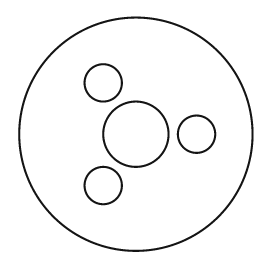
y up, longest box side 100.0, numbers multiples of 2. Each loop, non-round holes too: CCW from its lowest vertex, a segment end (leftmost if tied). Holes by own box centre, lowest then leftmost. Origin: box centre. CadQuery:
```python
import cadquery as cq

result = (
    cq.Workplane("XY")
    .moveTo(0.0, 0.0)
    .circle(50.0)
    .moveTo(-14.0, -22.0)
    .circle(8.0)
    .moveTo(0.0, 0.0)
    .circle(14.0)
    .moveTo(26.0, 0.0)
    .circle(8.0)
    .moveTo(-14.0, 22.0)
    .circle(8.0)
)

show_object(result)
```